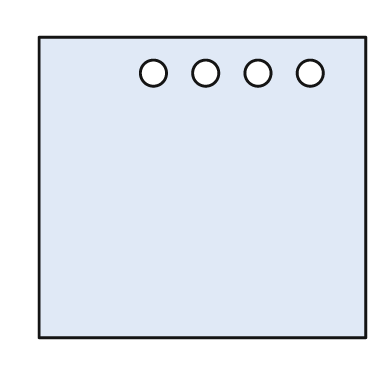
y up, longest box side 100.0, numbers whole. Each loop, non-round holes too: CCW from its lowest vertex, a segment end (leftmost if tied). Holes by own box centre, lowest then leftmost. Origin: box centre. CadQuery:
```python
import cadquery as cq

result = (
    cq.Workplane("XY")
    .moveTo(-50.0, -46.0)
    .lineTo(50.0, -46.0)
    .lineTo(50.0, 46.0)
    .lineTo(-50.0, 46.0)
    .close()
    .moveTo(-15.0, 35.0)
    .circle(4.0)
    .moveTo(1.0, 35.0)
    .circle(4.0)
    .moveTo(17.0, 35.0)
    .circle(4.0)
    .moveTo(33.0, 35.0)
    .circle(4.0)
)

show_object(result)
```